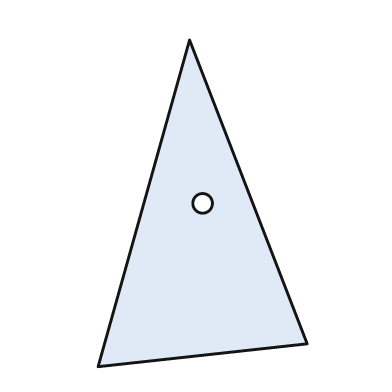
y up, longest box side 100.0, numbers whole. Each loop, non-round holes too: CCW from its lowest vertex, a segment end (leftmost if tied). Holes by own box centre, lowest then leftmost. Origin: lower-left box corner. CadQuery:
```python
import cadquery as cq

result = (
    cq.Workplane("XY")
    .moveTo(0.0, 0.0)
    .lineTo(64.0, 7.0)
    .lineTo(28.0, 100.0)
    .close()
    .moveTo(32.0, 50.0)
    .circle(3.0)
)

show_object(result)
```